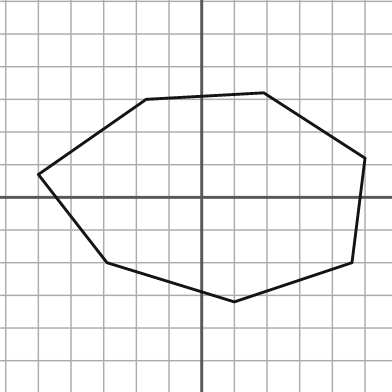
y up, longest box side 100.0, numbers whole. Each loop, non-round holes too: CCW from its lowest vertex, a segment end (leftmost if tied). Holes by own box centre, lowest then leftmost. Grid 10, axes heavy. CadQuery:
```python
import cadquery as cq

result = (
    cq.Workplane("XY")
    .moveTo(10.0, -32.0)
    .lineTo(46.0, -20.0)
    .lineTo(50.0, 12.0)
    .lineTo(19.0, 32.0)
    .lineTo(-17.0, 30.0)
    .lineTo(-50.0, 7.0)
    .lineTo(-29.0, -20.0)
    .close()
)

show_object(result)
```